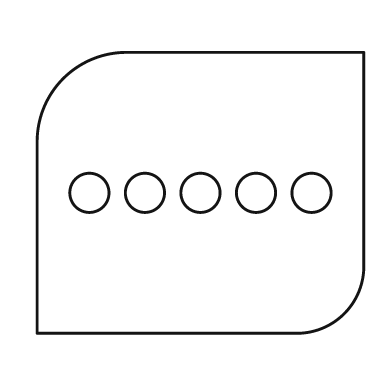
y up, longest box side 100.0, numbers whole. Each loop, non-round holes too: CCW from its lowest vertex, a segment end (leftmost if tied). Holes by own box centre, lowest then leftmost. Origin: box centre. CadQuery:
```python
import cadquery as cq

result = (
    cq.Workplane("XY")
    .moveTo(-50.0, -43.0)
    .lineTo(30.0, -43.0)
    .threePointArc((44.0, -37.0), (50.0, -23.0))
    .lineTo(50.0, 43.0)
    .lineTo(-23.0, 43.0)
    .threePointArc((-42.0, 35.0), (-50.0, 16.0))
    .close()
    .moveTo(-34.0, 0.0)
    .circle(6.0)
    .moveTo(-17.0, 0.0)
    .circle(6.0)
    .moveTo(0.0, 0.0)
    .circle(6.0)
    .moveTo(17.0, 0.0)
    .circle(6.0)
    .moveTo(34.0, 0.0)
    .circle(6.0)
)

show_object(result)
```